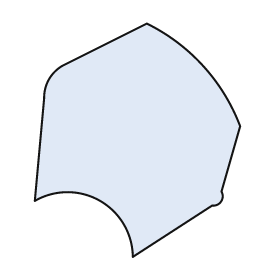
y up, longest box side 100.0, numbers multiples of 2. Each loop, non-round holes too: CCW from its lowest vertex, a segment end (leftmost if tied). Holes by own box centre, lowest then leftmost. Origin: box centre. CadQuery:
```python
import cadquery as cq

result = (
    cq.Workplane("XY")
    .moveTo(-2.0, -50.0)
    .lineTo(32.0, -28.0)
    .threePointArc((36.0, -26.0), (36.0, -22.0))
    .lineTo(44.0, 6.0)
    .threePointArc((28.0, 32.0), (4.0, 50.0))
    .lineTo(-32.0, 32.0)
    .threePointArc((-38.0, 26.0), (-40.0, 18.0))
    .lineTo(-44.0, -26.0)
    .threePointArc((-16.0, -26.0), (-2.0, -50.0))
    .close()
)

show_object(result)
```